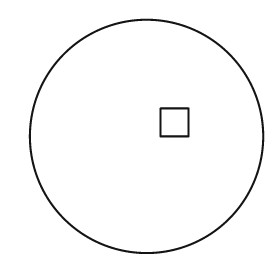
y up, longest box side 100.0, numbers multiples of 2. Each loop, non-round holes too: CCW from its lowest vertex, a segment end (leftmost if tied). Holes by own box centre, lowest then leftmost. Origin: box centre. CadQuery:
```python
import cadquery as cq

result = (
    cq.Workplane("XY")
    .moveTo(0.0, 0.0)
    .circle(50.0)
    .moveTo(6.0, 0.0)
    .lineTo(18.0, 0.0)
    .lineTo(18.0, 12.0)
    .lineTo(6.0, 12.0)
    .close()
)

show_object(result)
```